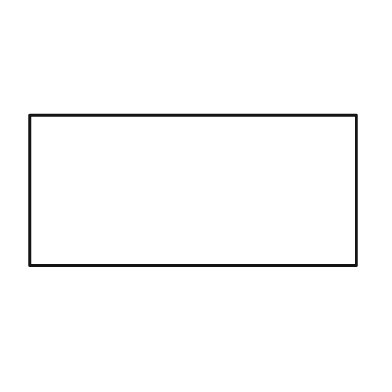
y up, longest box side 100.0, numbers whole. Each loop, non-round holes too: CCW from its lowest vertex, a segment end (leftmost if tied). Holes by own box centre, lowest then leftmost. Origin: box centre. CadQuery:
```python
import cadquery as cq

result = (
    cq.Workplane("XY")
    .moveTo(-50.0, -23.0)
    .lineTo(50.0, -23.0)
    .lineTo(50.0, 23.0)
    .lineTo(-50.0, 23.0)
    .close()
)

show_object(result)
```